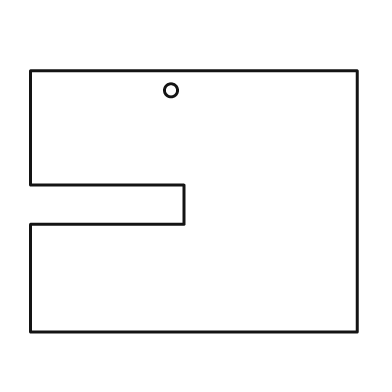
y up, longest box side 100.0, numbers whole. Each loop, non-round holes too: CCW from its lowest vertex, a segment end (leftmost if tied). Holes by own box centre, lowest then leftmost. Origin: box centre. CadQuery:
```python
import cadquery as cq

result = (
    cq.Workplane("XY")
    .moveTo(-50.0, -40.0)
    .lineTo(50.0, -40.0)
    .lineTo(50.0, 40.0)
    .lineTo(-50.0, 40.0)
    .lineTo(-50.0, 5.0)
    .lineTo(-3.0, 5.0)
    .lineTo(-3.0, -7.0)
    .lineTo(-50.0, -7.0)
    .close()
    .moveTo(-7.0, 34.0)
    .circle(2.0)
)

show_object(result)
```